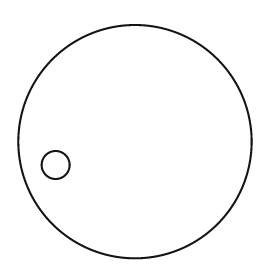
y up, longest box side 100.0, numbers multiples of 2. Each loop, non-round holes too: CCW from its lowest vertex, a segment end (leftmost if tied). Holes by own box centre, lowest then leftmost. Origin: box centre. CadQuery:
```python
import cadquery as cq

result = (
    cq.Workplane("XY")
    .moveTo(0.0, 0.0)
    .circle(50.0)
    .moveTo(-34.0, -10.0)
    .circle(6.0)
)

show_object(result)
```